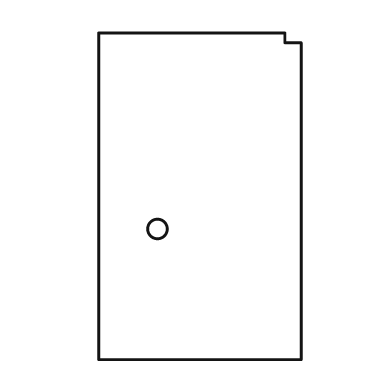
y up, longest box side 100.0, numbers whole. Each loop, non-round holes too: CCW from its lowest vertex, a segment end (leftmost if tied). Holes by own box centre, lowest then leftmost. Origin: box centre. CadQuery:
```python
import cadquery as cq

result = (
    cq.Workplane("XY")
    .moveTo(-31.0, -50.0)
    .lineTo(31.0, -50.0)
    .lineTo(31.0, 47.0)
    .lineTo(26.0, 47.0)
    .lineTo(26.0, 50.0)
    .lineTo(-31.0, 50.0)
    .close()
    .moveTo(-13.0, -10.0)
    .circle(3.0)
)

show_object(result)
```